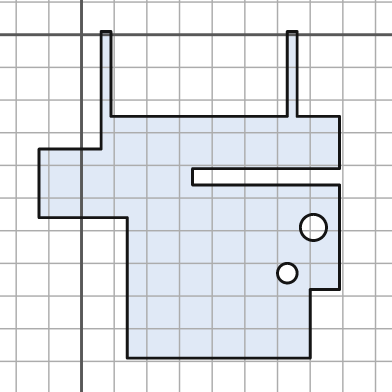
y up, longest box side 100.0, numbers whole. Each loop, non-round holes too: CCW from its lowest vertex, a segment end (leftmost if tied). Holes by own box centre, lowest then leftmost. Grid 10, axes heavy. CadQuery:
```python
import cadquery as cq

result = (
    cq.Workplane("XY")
    .moveTo(14.0, -99.0)
    .lineTo(70.0, -99.0)
    .lineTo(70.0, -78.0)
    .lineTo(79.0, -78.0)
    .lineTo(79.0, -46.0)
    .lineTo(34.0, -46.0)
    .lineTo(34.0, -41.0)
    .lineTo(79.0, -41.0)
    .lineTo(79.0, -25.0)
    .lineTo(66.0, -25.0)
    .lineTo(66.0, 1.0)
    .lineTo(63.0, 1.0)
    .lineTo(63.0, -25.0)
    .lineTo(9.0, -25.0)
    .lineTo(9.0, 1.0)
    .lineTo(6.0, 1.0)
    .lineTo(6.0, -35.0)
    .lineTo(-13.0, -35.0)
    .lineTo(-13.0, -56.0)
    .lineTo(14.0, -56.0)
    .close()
    .moveTo(63.0, -73.0)
    .circle(3.0)
    .moveTo(71.0, -59.0)
    .circle(4.0)
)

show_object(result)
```